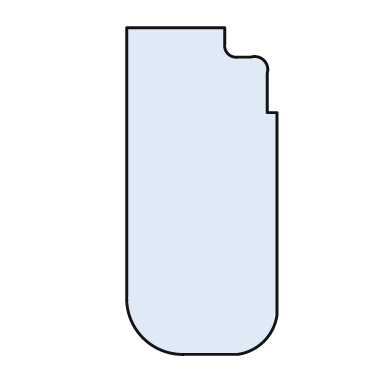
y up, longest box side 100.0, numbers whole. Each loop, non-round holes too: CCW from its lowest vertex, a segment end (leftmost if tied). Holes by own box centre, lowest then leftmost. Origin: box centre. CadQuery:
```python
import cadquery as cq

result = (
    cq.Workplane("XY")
    .moveTo(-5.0, -50.0)
    .lineTo(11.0, -50.0)
    .threePointArc((19.0, -46.0), (23.0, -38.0))
    .lineTo(23.0, 24.0)
    .lineTo(20.0, 24.0)
    .lineTo(20.0, 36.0)
    .threePointArc((19.0, 40.0), (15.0, 41.0))
    .lineTo(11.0, 41.0)
    .threePointArc((8.0, 42.0), (7.0, 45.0))
    .lineTo(7.0, 50.0)
    .lineTo(-23.0, 50.0)
    .lineTo(-23.0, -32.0)
    .threePointArc((-18.0, -45.0), (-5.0, -50.0))
    .close()
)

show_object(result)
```